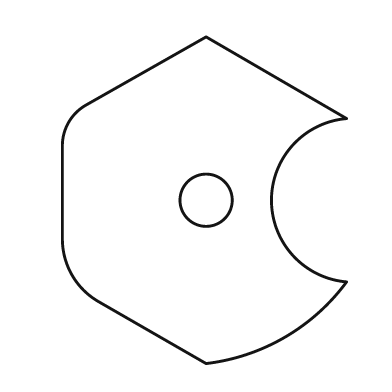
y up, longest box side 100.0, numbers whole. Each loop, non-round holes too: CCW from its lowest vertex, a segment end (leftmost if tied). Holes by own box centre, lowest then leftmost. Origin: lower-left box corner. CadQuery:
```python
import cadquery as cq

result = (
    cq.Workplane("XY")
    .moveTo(44.0, 0.0)
    .threePointArc((68.0, 8.0), (87.0, 25.0))
    .threePointArc((64.0, 50.0), (87.0, 75.0))
    .lineTo(44.0, 100.0)
    .lineTo(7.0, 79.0)
    .threePointArc((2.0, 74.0), (0.0, 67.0))
    .lineTo(0.0, 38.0)
    .threePointArc((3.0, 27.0), (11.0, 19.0))
    .close()
    .moveTo(44.0, 50.0)
    .circle(8.0)
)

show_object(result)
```